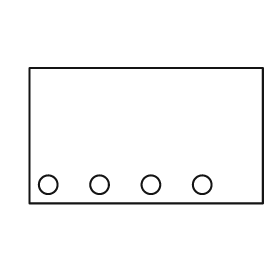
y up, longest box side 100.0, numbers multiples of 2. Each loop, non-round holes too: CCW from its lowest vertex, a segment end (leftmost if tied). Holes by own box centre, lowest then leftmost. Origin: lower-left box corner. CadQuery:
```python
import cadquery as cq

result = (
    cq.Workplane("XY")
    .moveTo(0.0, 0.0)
    .lineTo(100.0, 0.0)
    .lineTo(100.0, 58.0)
    .lineTo(0.0, 58.0)
    .close()
    .moveTo(8.0, 8.0)
    .circle(4.0)
    .moveTo(30.0, 8.0)
    .circle(4.0)
    .moveTo(52.0, 8.0)
    .circle(4.0)
    .moveTo(74.0, 8.0)
    .circle(4.0)
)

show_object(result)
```